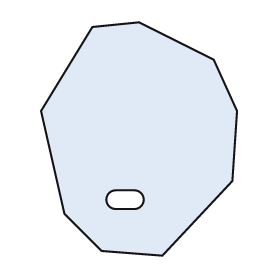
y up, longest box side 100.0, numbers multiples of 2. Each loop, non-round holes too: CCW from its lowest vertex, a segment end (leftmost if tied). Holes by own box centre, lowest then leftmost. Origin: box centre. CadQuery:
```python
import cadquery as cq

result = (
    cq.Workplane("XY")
    .moveTo(10.0, -50.0)
    .lineTo(40.0, -18.0)
    .lineTo(42.0, 12.0)
    .lineTo(32.0, 34.0)
    .lineTo(0.0, 50.0)
    .lineTo(-20.0, 48.0)
    .lineTo(-42.0, 12.0)
    .lineTo(-32.0, -32.0)
    .lineTo(-16.0, -48.0)
    .close()
    .moveTo(-10.0, -30.0)
    .lineTo(-2.0, -30.0)
    .threePointArc((2.0, -26.0), (-2.0, -22.0))
    .lineTo(-10.0, -22.0)
    .threePointArc((-14.0, -26.0), (-10.0, -30.0))
    .close()
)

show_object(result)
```